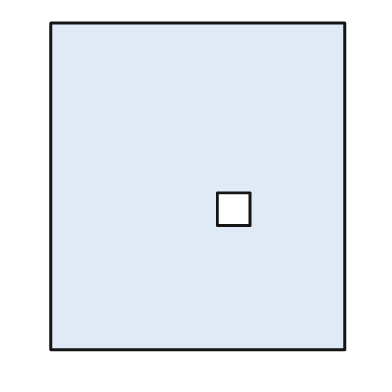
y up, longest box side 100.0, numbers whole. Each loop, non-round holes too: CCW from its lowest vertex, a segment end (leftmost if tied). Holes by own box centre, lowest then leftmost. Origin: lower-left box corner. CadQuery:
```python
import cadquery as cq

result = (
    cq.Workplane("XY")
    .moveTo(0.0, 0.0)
    .lineTo(90.0, 0.0)
    .lineTo(90.0, 100.0)
    .lineTo(0.0, 100.0)
    .close()
    .moveTo(51.0, 38.0)
    .lineTo(61.0, 38.0)
    .lineTo(61.0, 48.0)
    .lineTo(51.0, 48.0)
    .close()
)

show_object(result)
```